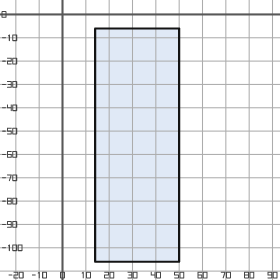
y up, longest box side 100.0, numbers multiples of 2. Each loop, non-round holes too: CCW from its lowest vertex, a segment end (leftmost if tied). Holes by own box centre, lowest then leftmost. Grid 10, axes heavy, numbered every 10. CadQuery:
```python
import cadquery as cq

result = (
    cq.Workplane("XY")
    .moveTo(14.0, -106.0)
    .lineTo(50.0, -106.0)
    .lineTo(50.0, -6.0)
    .lineTo(14.0, -6.0)
    .close()
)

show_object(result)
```